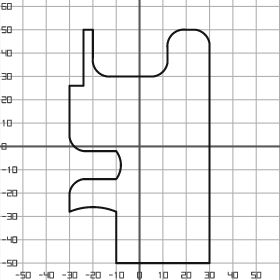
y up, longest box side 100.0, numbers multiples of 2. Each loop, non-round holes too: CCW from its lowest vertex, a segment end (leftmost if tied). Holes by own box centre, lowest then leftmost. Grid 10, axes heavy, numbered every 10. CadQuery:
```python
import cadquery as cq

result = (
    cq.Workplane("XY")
    .moveTo(-10.0, -50.0)
    .lineTo(30.0, -50.0)
    .lineTo(30.0, 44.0)
    .threePointArc((28.0, 48.0), (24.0, 50.0))
    .lineTo(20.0, 50.0)
    .threePointArc((14.0, 48.0), (12.0, 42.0))
    .lineTo(12.0, 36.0)
    .threePointArc((10.0, 32.0), (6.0, 30.0))
    .lineTo(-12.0, 30.0)
    .threePointArc((-18.0, 32.0), (-20.0, 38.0))
    .lineTo(-20.0, 50.0)
    .lineTo(-24.0, 50.0)
    .lineTo(-24.0, 26.0)
    .lineTo(-30.0, 26.0)
    .lineTo(-30.0, 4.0)
    .threePointArc((-28.0, 0.0), (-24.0, -2.0))
    .lineTo(-10.0, -2.0)
    .threePointArc((-8.0, -8.0), (-10.0, -14.0))
    .lineTo(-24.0, -14.0)
    .threePointArc((-28.0, -16.0), (-30.0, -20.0))
    .lineTo(-30.0, -28.0)
    .threePointArc((-20.0, -26.0), (-10.0, -28.0))
    .close()
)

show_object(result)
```